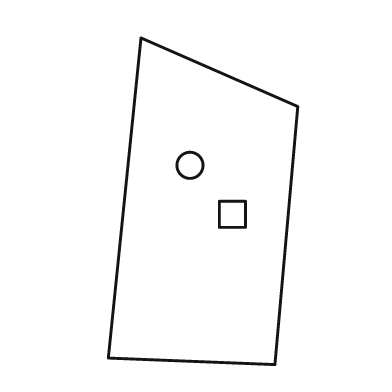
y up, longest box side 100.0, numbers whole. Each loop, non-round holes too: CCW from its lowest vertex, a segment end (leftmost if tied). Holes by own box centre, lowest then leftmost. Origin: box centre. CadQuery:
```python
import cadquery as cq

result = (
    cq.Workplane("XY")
    .moveTo(22.0, -50.0)
    .lineTo(29.0, 29.0)
    .lineTo(-19.0, 50.0)
    .lineTo(-29.0, -48.0)
    .close()
    .moveTo(5.0, -8.0)
    .lineTo(13.0, -8.0)
    .lineTo(13.0, 0.0)
    .lineTo(5.0, 0.0)
    .close()
    .moveTo(-4.0, 11.0)
    .circle(4.0)
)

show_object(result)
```